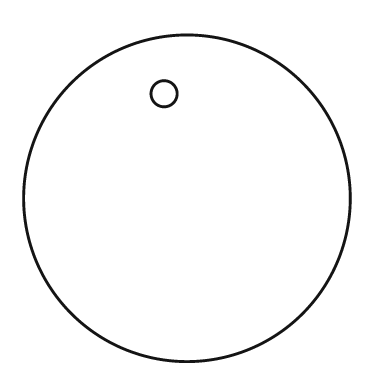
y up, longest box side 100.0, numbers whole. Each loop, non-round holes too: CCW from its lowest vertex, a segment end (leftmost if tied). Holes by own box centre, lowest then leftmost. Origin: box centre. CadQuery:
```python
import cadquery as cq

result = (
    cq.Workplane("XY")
    .moveTo(0.0, 0.0)
    .circle(50.0)
    .moveTo(-7.0, 32.0)
    .circle(4.0)
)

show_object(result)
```